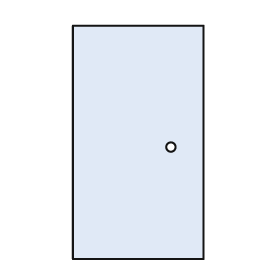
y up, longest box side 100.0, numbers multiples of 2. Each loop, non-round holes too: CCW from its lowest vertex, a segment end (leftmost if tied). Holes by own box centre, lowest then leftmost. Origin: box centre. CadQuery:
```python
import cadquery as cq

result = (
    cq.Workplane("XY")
    .moveTo(-28.0, -50.0)
    .lineTo(28.0, -50.0)
    .lineTo(28.0, 50.0)
    .lineTo(-28.0, 50.0)
    .close()
    .moveTo(14.0, -2.0)
    .circle(2.0)
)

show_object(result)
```